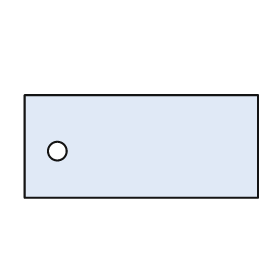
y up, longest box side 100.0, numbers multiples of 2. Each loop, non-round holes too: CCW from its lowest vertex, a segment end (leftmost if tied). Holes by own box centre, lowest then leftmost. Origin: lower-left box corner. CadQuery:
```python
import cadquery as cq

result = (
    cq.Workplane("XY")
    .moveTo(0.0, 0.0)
    .lineTo(100.0, 0.0)
    .lineTo(100.0, 44.0)
    .lineTo(0.0, 44.0)
    .close()
    .moveTo(14.0, 20.0)
    .circle(4.0)
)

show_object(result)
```